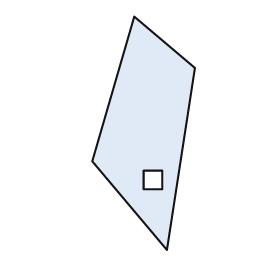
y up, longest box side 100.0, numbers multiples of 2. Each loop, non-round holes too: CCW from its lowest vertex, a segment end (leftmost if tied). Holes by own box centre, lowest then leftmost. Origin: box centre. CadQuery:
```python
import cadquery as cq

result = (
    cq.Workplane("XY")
    .moveTo(10.0, -50.0)
    .lineTo(22.0, 28.0)
    .lineTo(-4.0, 50.0)
    .lineTo(-22.0, -12.0)
    .close()
    .moveTo(0.0, -24.0)
    .lineTo(8.0, -24.0)
    .lineTo(8.0, -16.0)
    .lineTo(0.0, -16.0)
    .close()
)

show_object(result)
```